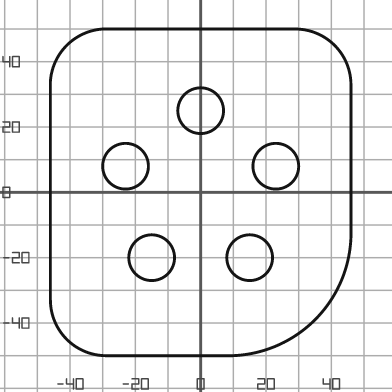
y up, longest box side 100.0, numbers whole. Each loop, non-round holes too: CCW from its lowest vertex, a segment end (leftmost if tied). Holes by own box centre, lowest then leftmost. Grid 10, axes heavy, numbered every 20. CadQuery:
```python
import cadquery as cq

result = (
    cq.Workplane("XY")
    .moveTo(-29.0, -50.0)
    .lineTo(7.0, -50.0)
    .threePointArc((35.0, -39.0), (46.0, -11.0))
    .lineTo(46.0, 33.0)
    .threePointArc((41.0, 45.0), (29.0, 50.0))
    .lineTo(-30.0, 50.0)
    .threePointArc((-41.0, 45.0), (-46.0, 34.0))
    .lineTo(-46.0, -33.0)
    .threePointArc((-41.0, -45.0), (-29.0, -50.0))
    .close()
    .moveTo(-15.0, -20.0)
    .circle(7.0)
    .moveTo(15.0, -20.0)
    .circle(7.0)
    .moveTo(-23.0, 8.0)
    .circle(7.0)
    .moveTo(23.0, 8.0)
    .circle(7.0)
    .moveTo(0.0, 25.0)
    .circle(7.0)
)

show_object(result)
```